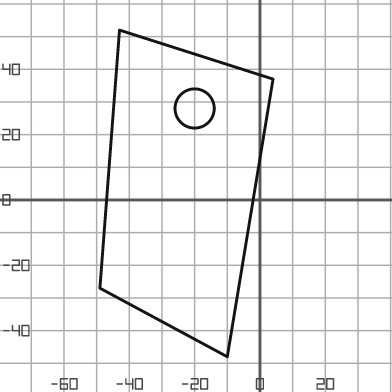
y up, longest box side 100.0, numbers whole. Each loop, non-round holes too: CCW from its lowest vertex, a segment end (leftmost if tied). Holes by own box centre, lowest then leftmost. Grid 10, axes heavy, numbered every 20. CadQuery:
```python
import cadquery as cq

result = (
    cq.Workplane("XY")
    .moveTo(-10.0, -48.0)
    .lineTo(4.0, 37.0)
    .lineTo(-43.0, 52.0)
    .lineTo(-49.0, -27.0)
    .close()
    .moveTo(-20.0, 28.0)
    .circle(6.0)
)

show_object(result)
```